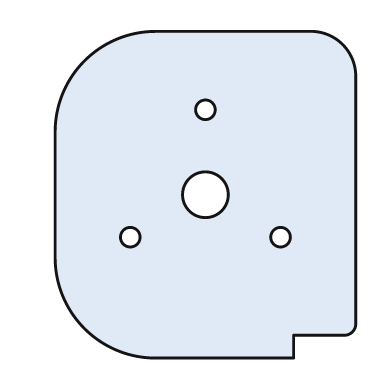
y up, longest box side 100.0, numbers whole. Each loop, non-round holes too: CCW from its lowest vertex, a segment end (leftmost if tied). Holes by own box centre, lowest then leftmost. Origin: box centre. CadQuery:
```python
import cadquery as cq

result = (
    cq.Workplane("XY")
    .moveTo(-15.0, -50.0)
    .lineTo(27.0, -50.0)
    .lineTo(27.0, -43.0)
    .lineTo(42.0, -43.0)
    .threePointArc((45.0, -42.0), (46.0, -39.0))
    .lineTo(46.0, 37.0)
    .threePointArc((42.0, 46.0), (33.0, 50.0))
    .lineTo(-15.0, 50.0)
    .threePointArc((-37.0, 41.0), (-46.0, 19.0))
    .lineTo(-46.0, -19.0)
    .threePointArc((-37.0, -41.0), (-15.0, -50.0))
    .close()
    .moveTo(-23.0, -13.0)
    .circle(3.0)
    .moveTo(23.0, -13.0)
    .circle(3.0)
    .moveTo(0.0, 0.0)
    .circle(7.0)
    .moveTo(0.0, 26.0)
    .circle(3.0)
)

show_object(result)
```